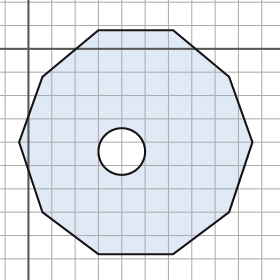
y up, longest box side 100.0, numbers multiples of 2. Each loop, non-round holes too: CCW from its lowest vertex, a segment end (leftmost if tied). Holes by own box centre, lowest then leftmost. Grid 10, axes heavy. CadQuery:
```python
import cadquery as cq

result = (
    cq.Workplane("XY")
    .moveTo(30.0, -88.0)
    .lineTo(62.0, -88.0)
    .lineTo(86.0, -70.0)
    .lineTo(96.0, -40.0)
    .lineTo(86.0, -12.0)
    .lineTo(62.0, 8.0)
    .lineTo(30.0, 8.0)
    .lineTo(6.0, -12.0)
    .lineTo(-4.0, -40.0)
    .lineTo(6.0, -70.0)
    .close()
    .moveTo(40.0, -44.0)
    .circle(10.0)
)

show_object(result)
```